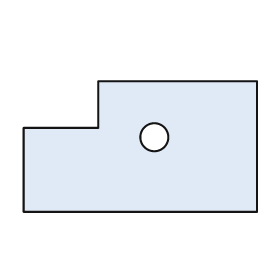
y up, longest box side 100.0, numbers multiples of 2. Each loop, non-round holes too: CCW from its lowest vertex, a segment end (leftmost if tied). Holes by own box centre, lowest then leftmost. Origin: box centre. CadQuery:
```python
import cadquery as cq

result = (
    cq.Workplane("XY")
    .moveTo(-50.0, -28.0)
    .lineTo(50.0, -28.0)
    .lineTo(50.0, 28.0)
    .lineTo(-18.0, 28.0)
    .lineTo(-18.0, 8.0)
    .lineTo(-50.0, 8.0)
    .close()
    .moveTo(6.0, 4.0)
    .circle(6.0)
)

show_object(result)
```